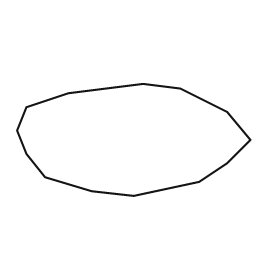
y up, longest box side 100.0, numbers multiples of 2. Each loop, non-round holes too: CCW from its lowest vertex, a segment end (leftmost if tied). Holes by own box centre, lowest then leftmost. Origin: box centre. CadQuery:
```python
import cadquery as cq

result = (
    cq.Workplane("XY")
    .moveTo(0.0, -24.0)
    .lineTo(28.0, -18.0)
    .lineTo(40.0, -10.0)
    .lineTo(50.0, 0.0)
    .lineTo(40.0, 12.0)
    .lineTo(20.0, 22.0)
    .lineTo(4.0, 24.0)
    .lineTo(-28.0, 20.0)
    .lineTo(-46.0, 14.0)
    .lineTo(-50.0, 4.0)
    .lineTo(-46.0, -6.0)
    .lineTo(-38.0, -16.0)
    .lineTo(-18.0, -22.0)
    .close()
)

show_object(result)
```